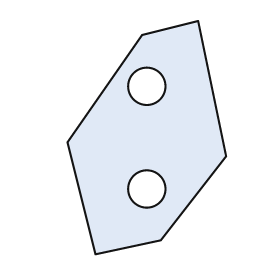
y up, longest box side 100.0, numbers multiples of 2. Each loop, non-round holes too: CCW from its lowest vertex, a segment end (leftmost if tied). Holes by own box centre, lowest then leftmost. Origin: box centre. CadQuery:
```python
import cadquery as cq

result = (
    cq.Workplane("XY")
    .moveTo(-22.0, -50.0)
    .lineTo(6.0, -44.0)
    .lineTo(34.0, -8.0)
    .lineTo(22.0, 50.0)
    .lineTo(-2.0, 44.0)
    .lineTo(-34.0, -2.0)
    .close()
    .moveTo(0.0, -22.0)
    .circle(8.0)
    .moveTo(0.0, 22.0)
    .circle(8.0)
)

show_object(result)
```